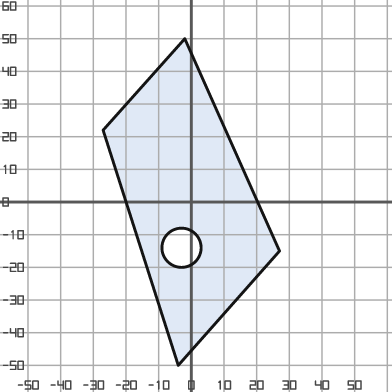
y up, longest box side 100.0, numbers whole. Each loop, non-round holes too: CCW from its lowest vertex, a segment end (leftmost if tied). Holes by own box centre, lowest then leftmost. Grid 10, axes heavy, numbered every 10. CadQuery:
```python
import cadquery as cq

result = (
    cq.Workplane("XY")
    .moveTo(-4.0, -50.0)
    .lineTo(27.0, -15.0)
    .lineTo(-2.0, 50.0)
    .lineTo(-27.0, 22.0)
    .close()
    .moveTo(-3.0, -14.0)
    .circle(6.0)
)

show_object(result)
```